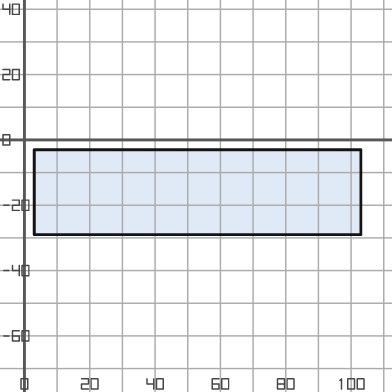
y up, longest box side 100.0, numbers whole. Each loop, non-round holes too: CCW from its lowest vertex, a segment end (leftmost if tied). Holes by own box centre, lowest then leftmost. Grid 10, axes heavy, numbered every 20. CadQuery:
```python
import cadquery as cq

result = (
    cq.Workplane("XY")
    .moveTo(3.0, -29.0)
    .lineTo(103.0, -29.0)
    .lineTo(103.0, -3.0)
    .lineTo(3.0, -3.0)
    .close()
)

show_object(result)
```